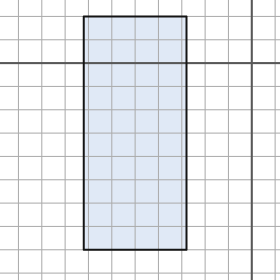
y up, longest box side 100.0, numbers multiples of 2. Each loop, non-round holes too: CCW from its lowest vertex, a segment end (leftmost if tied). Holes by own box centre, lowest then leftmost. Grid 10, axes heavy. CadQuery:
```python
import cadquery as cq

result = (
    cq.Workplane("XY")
    .moveTo(-72.0, -80.0)
    .lineTo(-28.0, -80.0)
    .lineTo(-28.0, 20.0)
    .lineTo(-72.0, 20.0)
    .close()
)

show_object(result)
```